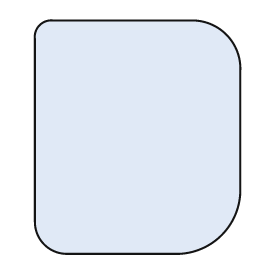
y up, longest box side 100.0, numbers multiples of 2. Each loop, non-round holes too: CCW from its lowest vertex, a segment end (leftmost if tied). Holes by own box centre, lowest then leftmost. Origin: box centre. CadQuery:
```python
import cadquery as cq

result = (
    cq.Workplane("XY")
    .moveTo(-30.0, -50.0)
    .lineTo(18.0, -50.0)
    .threePointArc((36.0, -42.0), (44.0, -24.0))
    .lineTo(44.0, 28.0)
    .threePointArc((38.0, 44.0), (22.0, 50.0))
    .lineTo(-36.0, 50.0)
    .threePointArc((-42.0, 48.0), (-44.0, 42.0))
    .lineTo(-44.0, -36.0)
    .threePointArc((-40.0, -46.0), (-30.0, -50.0))
    .close()
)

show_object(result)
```